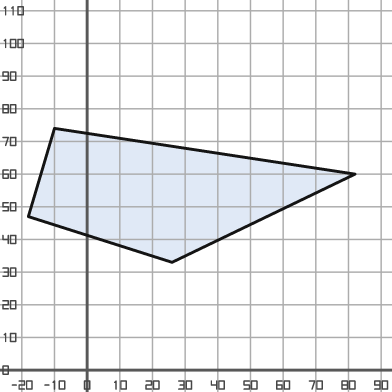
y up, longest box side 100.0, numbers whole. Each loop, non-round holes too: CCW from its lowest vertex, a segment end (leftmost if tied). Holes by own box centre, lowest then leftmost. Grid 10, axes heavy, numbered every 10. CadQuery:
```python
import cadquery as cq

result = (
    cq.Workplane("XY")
    .moveTo(26.0, 33.0)
    .lineTo(82.0, 60.0)
    .lineTo(-10.0, 74.0)
    .lineTo(-18.0, 47.0)
    .close()
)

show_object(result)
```